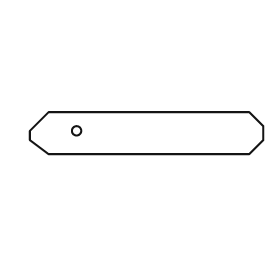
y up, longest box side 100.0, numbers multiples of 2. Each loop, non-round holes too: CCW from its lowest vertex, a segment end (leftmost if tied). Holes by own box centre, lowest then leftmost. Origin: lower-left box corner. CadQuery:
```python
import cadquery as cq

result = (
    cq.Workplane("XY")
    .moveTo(8.0, 0.0)
    .lineTo(94.0, 0.0)
    .lineTo(100.0, 6.0)
    .lineTo(100.0, 12.0)
    .lineTo(94.0, 18.0)
    .lineTo(8.0, 18.0)
    .lineTo(0.0, 10.0)
    .lineTo(0.0, 6.0)
    .close()
    .moveTo(20.0, 10.0)
    .circle(2.0)
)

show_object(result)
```